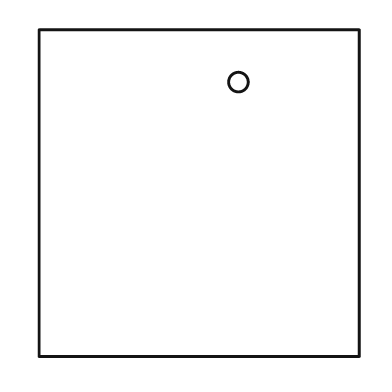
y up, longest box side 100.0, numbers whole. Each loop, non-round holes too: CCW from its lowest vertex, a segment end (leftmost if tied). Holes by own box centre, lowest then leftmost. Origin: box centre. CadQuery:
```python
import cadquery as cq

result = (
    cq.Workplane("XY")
    .moveTo(-49.0, -50.0)
    .lineTo(49.0, -50.0)
    .lineTo(49.0, 50.0)
    .lineTo(-49.0, 50.0)
    .close()
    .moveTo(12.0, 34.0)
    .circle(3.0)
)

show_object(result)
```